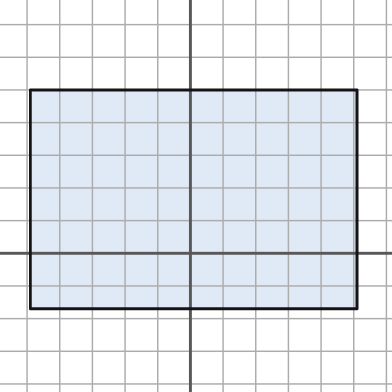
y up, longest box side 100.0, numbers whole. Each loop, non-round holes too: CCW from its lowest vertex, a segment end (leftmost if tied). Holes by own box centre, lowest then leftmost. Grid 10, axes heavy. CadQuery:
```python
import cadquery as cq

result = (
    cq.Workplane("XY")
    .moveTo(-49.0, -17.0)
    .lineTo(51.0, -17.0)
    .lineTo(51.0, 50.0)
    .lineTo(-49.0, 50.0)
    .close()
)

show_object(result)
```